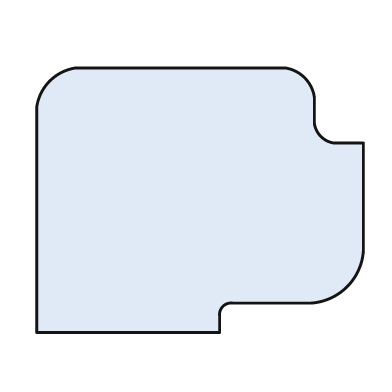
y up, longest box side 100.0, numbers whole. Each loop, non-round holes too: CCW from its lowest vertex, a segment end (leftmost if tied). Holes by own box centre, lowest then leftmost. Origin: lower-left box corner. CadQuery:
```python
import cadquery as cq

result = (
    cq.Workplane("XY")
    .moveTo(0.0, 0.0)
    .lineTo(56.0, 0.0)
    .lineTo(56.0, 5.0)
    .threePointArc((57.0, 8.0), (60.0, 9.0))
    .lineTo(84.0, 9.0)
    .threePointArc((95.0, 14.0), (100.0, 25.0))
    .lineTo(100.0, 58.0)
    .lineTo(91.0, 58.0)
    .threePointArc((87.0, 60.0), (85.0, 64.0))
    .lineTo(85.0, 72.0)
    .threePointArc((82.0, 78.0), (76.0, 81.0))
    .lineTo(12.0, 81.0)
    .threePointArc((4.0, 77.0), (0.0, 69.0))
    .close()
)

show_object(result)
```